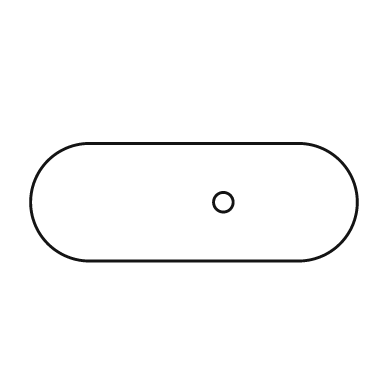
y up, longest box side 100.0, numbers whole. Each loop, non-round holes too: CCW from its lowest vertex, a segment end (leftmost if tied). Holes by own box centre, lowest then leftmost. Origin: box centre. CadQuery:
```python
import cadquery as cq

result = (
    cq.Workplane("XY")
    .moveTo(-32.0, -18.0)
    .lineTo(32.0, -18.0)
    .threePointArc((50.0, 0.0), (32.0, 18.0))
    .lineTo(-32.0, 18.0)
    .threePointArc((-50.0, 0.0), (-32.0, -18.0))
    .close()
    .moveTo(9.0, 0.0)
    .circle(3.0)
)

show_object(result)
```